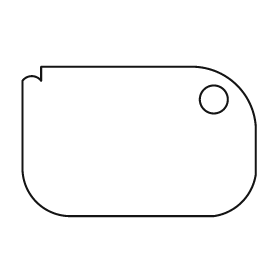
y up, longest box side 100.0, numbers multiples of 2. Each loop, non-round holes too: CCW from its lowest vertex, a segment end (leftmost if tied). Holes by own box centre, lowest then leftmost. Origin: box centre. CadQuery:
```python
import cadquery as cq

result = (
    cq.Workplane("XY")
    .moveTo(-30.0, -32.0)
    .lineTo(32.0, -32.0)
    .threePointArc((44.0, -26.0), (50.0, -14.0))
    .lineTo(50.0, 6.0)
    .threePointArc((42.0, 24.0), (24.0, 32.0))
    .lineTo(-42.0, 32.0)
    .lineTo(-42.0, 26.0)
    .threePointArc((-46.0, 28.0), (-50.0, 26.0))
    .lineTo(-50.0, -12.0)
    .threePointArc((-44.0, -26.0), (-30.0, -32.0))
    .close()
    .moveTo(32.0, 18.0)
    .circle(6.0)
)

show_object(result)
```